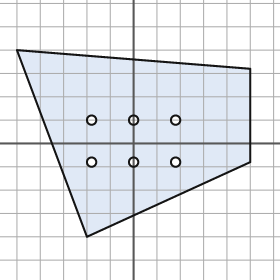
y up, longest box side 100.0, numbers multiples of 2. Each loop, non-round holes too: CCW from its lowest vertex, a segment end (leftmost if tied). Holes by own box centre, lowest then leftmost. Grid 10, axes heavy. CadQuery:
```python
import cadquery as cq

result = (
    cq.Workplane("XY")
    .moveTo(-20.0, -40.0)
    .lineTo(50.0, -8.0)
    .lineTo(50.0, 32.0)
    .lineTo(-50.0, 40.0)
    .close()
    .moveTo(-18.0, -8.0)
    .circle(2.0)
    .moveTo(0.0, -8.0)
    .circle(2.0)
    .moveTo(18.0, -8.0)
    .circle(2.0)
    .moveTo(-18.0, 10.0)
    .circle(2.0)
    .moveTo(0.0, 10.0)
    .circle(2.0)
    .moveTo(18.0, 10.0)
    .circle(2.0)
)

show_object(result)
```